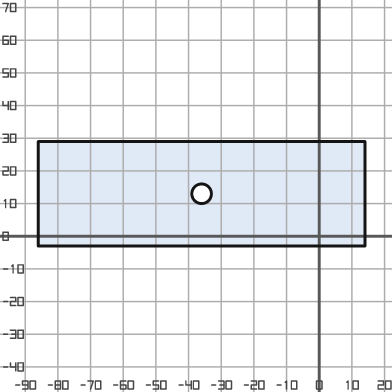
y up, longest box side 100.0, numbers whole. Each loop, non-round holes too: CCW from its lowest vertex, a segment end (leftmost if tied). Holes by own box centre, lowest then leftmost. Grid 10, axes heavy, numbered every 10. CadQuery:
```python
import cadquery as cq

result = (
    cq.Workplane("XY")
    .moveTo(-86.0, -3.0)
    .lineTo(14.0, -3.0)
    .lineTo(14.0, 29.0)
    .lineTo(-86.0, 29.0)
    .close()
    .moveTo(-36.0, 13.0)
    .circle(3.0)
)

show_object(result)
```